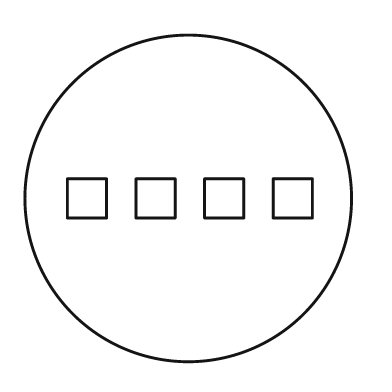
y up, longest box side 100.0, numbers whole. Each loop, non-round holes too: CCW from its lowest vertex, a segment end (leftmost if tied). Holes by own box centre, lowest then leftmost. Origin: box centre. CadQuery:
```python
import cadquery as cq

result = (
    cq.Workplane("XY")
    .moveTo(0.0, 0.0)
    .circle(50.0)
    .moveTo(-37.0, -6.0)
    .lineTo(-25.0, -6.0)
    .lineTo(-25.0, 6.0)
    .lineTo(-37.0, 6.0)
    .close()
    .moveTo(-16.0, -6.0)
    .lineTo(-4.0, -6.0)
    .lineTo(-4.0, 6.0)
    .lineTo(-16.0, 6.0)
    .close()
    .moveTo(5.0, -6.0)
    .lineTo(17.0, -6.0)
    .lineTo(17.0, 6.0)
    .lineTo(5.0, 6.0)
    .close()
    .moveTo(26.0, -6.0)
    .lineTo(38.0, -6.0)
    .lineTo(38.0, 6.0)
    .lineTo(26.0, 6.0)
    .close()
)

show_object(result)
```